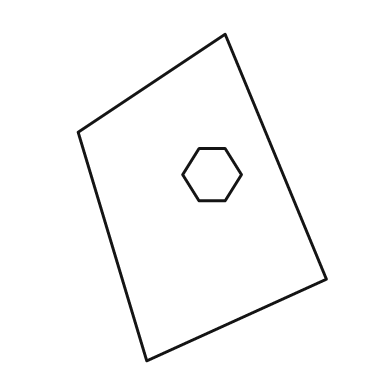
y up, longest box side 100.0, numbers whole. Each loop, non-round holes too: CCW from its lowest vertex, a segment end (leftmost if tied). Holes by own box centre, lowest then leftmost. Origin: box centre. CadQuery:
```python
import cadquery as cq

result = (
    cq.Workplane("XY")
    .moveTo(-17.0, -50.0)
    .lineTo(38.0, -25.0)
    .lineTo(7.0, 50.0)
    .lineTo(-38.0, 20.0)
    .close()
    .moveTo(-1.0, -1.0)
    .lineTo(7.0, -1.0)
    .lineTo(12.0, 7.0)
    .lineTo(7.0, 15.0)
    .lineTo(-1.0, 15.0)
    .lineTo(-6.0, 7.0)
    .close()
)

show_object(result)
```